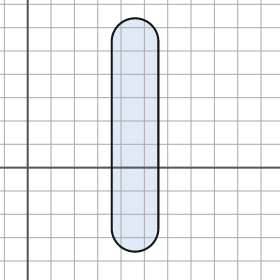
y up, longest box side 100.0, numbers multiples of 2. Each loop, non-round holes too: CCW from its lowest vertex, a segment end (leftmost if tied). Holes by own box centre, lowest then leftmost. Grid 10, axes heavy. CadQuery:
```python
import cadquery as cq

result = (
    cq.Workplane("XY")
    .moveTo(36.0, -26.0)
    .threePointArc((46.0, -36.0), (56.0, -26.0))
    .lineTo(56.0, 54.0)
    .threePointArc((46.0, 64.0), (36.0, 54.0))
    .close()
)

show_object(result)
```